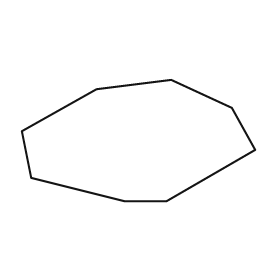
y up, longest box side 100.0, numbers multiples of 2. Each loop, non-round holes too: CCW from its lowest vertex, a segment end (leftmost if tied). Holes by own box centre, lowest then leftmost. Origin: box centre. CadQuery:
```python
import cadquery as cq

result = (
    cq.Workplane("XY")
    .moveTo(-6.0, -26.0)
    .lineTo(12.0, -26.0)
    .lineTo(50.0, -4.0)
    .lineTo(40.0, 14.0)
    .lineTo(14.0, 26.0)
    .lineTo(-18.0, 22.0)
    .lineTo(-50.0, 4.0)
    .lineTo(-46.0, -16.0)
    .close()
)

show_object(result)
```